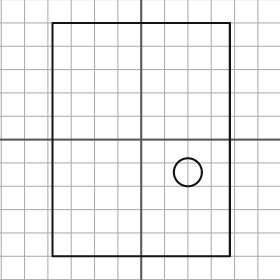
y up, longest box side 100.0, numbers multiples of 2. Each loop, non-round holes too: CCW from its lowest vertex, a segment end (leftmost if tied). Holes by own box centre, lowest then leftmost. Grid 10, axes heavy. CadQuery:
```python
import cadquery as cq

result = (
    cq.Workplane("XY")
    .moveTo(-38.0, -50.0)
    .lineTo(38.0, -50.0)
    .lineTo(38.0, 50.0)
    .lineTo(-38.0, 50.0)
    .close()
    .moveTo(20.0, -14.0)
    .circle(6.0)
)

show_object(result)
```